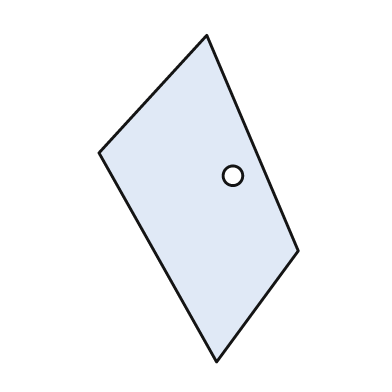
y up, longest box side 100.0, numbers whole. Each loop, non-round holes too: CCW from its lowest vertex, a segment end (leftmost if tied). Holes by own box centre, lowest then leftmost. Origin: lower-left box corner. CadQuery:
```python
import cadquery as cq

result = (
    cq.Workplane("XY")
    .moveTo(36.0, 0.0)
    .lineTo(61.0, 34.0)
    .lineTo(33.0, 100.0)
    .lineTo(0.0, 64.0)
    .close()
    .moveTo(41.0, 57.0)
    .circle(3.0)
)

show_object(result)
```